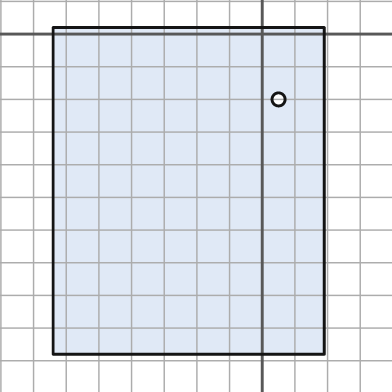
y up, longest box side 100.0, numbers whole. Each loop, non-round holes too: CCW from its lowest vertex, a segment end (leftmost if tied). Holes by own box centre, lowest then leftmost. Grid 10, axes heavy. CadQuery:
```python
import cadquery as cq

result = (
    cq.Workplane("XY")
    .moveTo(-64.0, -98.0)
    .lineTo(19.0, -98.0)
    .lineTo(19.0, 2.0)
    .lineTo(-64.0, 2.0)
    .close()
    .moveTo(5.0, -20.0)
    .circle(2.0)
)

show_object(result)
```